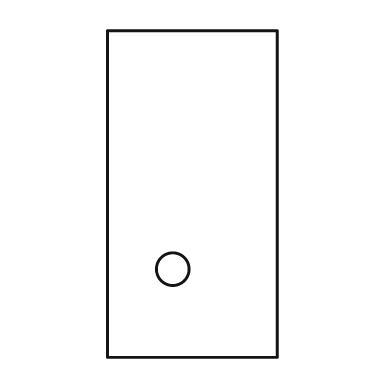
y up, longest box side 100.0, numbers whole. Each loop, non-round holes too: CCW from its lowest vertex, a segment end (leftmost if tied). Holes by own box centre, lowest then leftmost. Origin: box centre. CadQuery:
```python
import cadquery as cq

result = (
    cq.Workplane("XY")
    .moveTo(-26.0, -50.0)
    .lineTo(26.0, -50.0)
    .lineTo(26.0, 50.0)
    .lineTo(-26.0, 50.0)
    .close()
    .moveTo(-6.0, -23.0)
    .circle(5.0)
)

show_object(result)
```